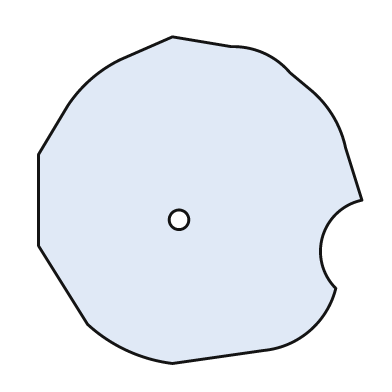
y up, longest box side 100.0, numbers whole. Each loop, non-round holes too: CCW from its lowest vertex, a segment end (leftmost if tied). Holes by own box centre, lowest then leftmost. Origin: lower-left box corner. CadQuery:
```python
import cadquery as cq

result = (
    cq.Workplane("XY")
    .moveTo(41.0, 0.0)
    .lineTo(69.0, 4.0)
    .threePointArc((83.0, 10.0), (91.0, 23.0))
    .threePointArc((87.0, 39.0), (99.0, 50.0))
    .lineTo(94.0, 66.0)
    .threePointArc((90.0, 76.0), (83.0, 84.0))
    .lineTo(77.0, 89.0)
    .threePointArc((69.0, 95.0), (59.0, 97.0))
    .lineTo(41.0, 100.0)
    .lineTo(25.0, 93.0)
    .threePointArc((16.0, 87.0), (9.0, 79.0))
    .lineTo(0.0, 64.0)
    .lineTo(0.0, 36.0)
    .lineTo(15.0, 12.0)
    .threePointArc((27.0, 4.0), (41.0, 0.0))
    .close()
    .moveTo(43.0, 44.0)
    .circle(3.0)
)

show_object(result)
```